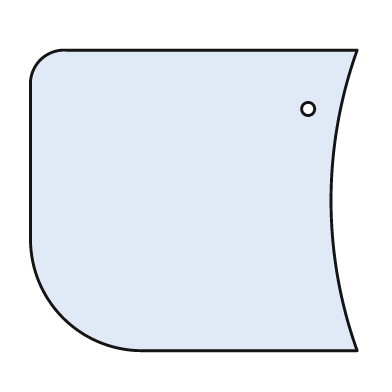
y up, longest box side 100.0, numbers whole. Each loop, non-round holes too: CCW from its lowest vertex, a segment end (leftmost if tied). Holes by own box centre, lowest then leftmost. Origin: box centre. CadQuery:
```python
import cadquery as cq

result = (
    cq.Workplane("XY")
    .moveTo(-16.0, -46.0)
    .lineTo(50.0, -46.0)
    .threePointArc((42.0, 0.0), (50.0, 46.0))
    .lineTo(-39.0, 46.0)
    .threePointArc((-47.0, 43.0), (-50.0, 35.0))
    .lineTo(-50.0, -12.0)
    .threePointArc((-40.0, -36.0), (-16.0, -46.0))
    .close()
    .moveTo(35.0, 28.0)
    .circle(2.0)
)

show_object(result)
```